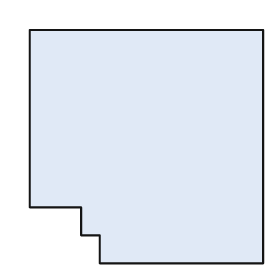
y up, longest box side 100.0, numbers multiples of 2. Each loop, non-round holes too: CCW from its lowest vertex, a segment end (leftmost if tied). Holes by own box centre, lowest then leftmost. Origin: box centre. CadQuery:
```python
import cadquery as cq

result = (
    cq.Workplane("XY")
    .moveTo(-20.0, -50.0)
    .lineTo(50.0, -50.0)
    .lineTo(50.0, 50.0)
    .lineTo(-50.0, 50.0)
    .lineTo(-50.0, -26.0)
    .lineTo(-28.0, -26.0)
    .lineTo(-28.0, -38.0)
    .lineTo(-20.0, -38.0)
    .close()
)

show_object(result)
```